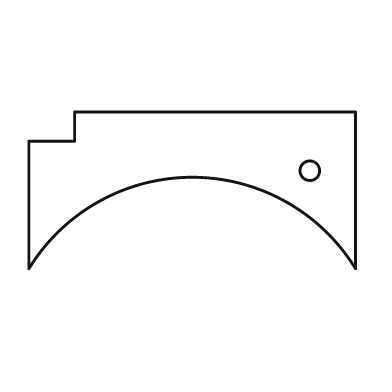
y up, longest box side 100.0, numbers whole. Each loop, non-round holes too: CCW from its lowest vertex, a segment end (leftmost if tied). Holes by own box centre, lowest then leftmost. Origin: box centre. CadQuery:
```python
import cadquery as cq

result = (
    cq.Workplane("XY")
    .moveTo(-50.0, -24.0)
    .threePointArc((0.0, 4.0), (50.0, -24.0))
    .lineTo(50.0, 24.0)
    .lineTo(-36.0, 24.0)
    .lineTo(-36.0, 15.0)
    .lineTo(-50.0, 15.0)
    .close()
    .moveTo(36.0, 6.0)
    .circle(3.0)
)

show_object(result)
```